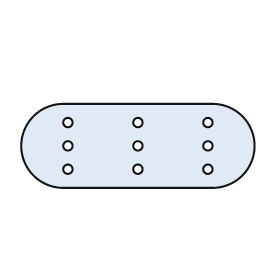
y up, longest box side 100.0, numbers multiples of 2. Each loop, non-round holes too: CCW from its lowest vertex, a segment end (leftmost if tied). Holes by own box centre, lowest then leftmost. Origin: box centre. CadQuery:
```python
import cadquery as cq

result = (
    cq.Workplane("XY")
    .moveTo(-32.0, -18.0)
    .lineTo(32.0, -18.0)
    .threePointArc((50.0, 0.0), (32.0, 18.0))
    .lineTo(-32.0, 18.0)
    .threePointArc((-50.0, 0.0), (-32.0, -18.0))
    .close()
    .moveTo(-30.0, -10.0)
    .circle(2.0)
    .moveTo(0.0, -10.0)
    .circle(2.0)
    .moveTo(30.0, -10.0)
    .circle(2.0)
    .moveTo(-30.0, 0.0)
    .circle(2.0)
    .moveTo(0.0, 0.0)
    .circle(2.0)
    .moveTo(30.0, 0.0)
    .circle(2.0)
    .moveTo(-30.0, 10.0)
    .circle(2.0)
    .moveTo(0.0, 10.0)
    .circle(2.0)
    .moveTo(30.0, 10.0)
    .circle(2.0)
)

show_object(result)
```